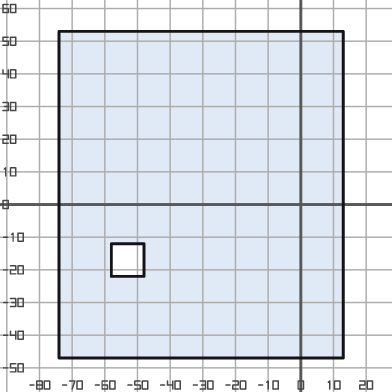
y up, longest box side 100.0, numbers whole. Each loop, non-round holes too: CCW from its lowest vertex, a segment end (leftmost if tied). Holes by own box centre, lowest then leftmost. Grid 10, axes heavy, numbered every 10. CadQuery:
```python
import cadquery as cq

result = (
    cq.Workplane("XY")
    .moveTo(-74.0, -47.0)
    .lineTo(13.0, -47.0)
    .lineTo(13.0, 53.0)
    .lineTo(-74.0, 53.0)
    .close()
    .moveTo(-58.0, -22.0)
    .lineTo(-48.0, -22.0)
    .lineTo(-48.0, -12.0)
    .lineTo(-58.0, -12.0)
    .close()
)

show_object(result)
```